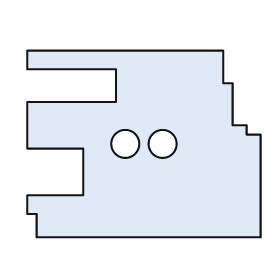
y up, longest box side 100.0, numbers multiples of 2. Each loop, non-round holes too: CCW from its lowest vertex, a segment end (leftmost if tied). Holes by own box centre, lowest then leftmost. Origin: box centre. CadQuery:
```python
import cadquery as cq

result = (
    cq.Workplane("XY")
    .moveTo(-46.0, -40.0)
    .lineTo(50.0, -40.0)
    .lineTo(50.0, 4.0)
    .lineTo(44.0, 4.0)
    .lineTo(44.0, 8.0)
    .lineTo(38.0, 8.0)
    .lineTo(38.0, 26.0)
    .lineTo(34.0, 26.0)
    .lineTo(34.0, 40.0)
    .lineTo(-50.0, 40.0)
    .lineTo(-50.0, 32.0)
    .lineTo(-12.0, 32.0)
    .lineTo(-12.0, 18.0)
    .lineTo(-50.0, 18.0)
    .lineTo(-50.0, -2.0)
    .lineTo(-26.0, -2.0)
    .lineTo(-26.0, -22.0)
    .lineTo(-50.0, -22.0)
    .lineTo(-50.0, -30.0)
    .lineTo(-46.0, -30.0)
    .close()
    .moveTo(-8.0, 0.0)
    .circle(6.0)
    .moveTo(8.0, 0.0)
    .circle(6.0)
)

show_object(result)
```